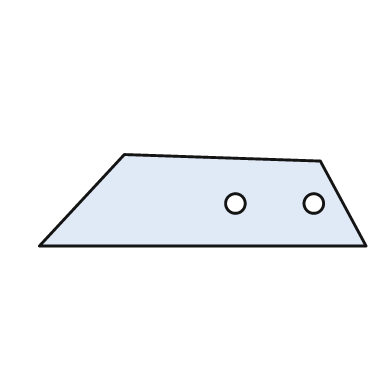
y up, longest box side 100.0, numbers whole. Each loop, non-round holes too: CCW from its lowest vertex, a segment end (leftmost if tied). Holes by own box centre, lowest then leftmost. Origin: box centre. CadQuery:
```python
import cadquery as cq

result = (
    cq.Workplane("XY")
    .moveTo(-50.0, -14.0)
    .lineTo(50.0, -14.0)
    .lineTo(36.0, 12.0)
    .lineTo(-24.0, 14.0)
    .close()
    .moveTo(10.0, -1.0)
    .circle(3.0)
    .moveTo(34.0, -1.0)
    .circle(3.0)
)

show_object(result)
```